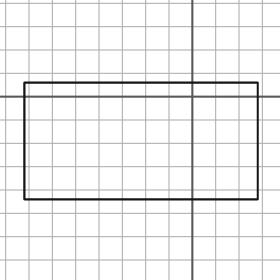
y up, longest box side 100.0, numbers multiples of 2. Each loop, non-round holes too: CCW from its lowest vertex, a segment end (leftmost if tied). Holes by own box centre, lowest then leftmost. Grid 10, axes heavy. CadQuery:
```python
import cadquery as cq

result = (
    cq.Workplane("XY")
    .moveTo(-72.0, -44.0)
    .lineTo(28.0, -44.0)
    .lineTo(28.0, 6.0)
    .lineTo(-72.0, 6.0)
    .close()
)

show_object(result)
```